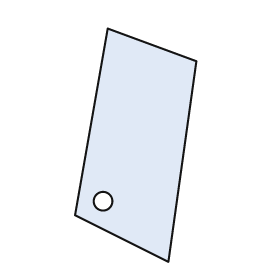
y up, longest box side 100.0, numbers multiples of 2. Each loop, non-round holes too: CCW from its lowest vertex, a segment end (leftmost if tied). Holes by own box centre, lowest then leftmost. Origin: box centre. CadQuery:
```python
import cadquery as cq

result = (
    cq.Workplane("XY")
    .moveTo(14.0, -50.0)
    .lineTo(26.0, 36.0)
    .lineTo(-12.0, 50.0)
    .lineTo(-26.0, -30.0)
    .close()
    .moveTo(-14.0, -24.0)
    .circle(4.0)
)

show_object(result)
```